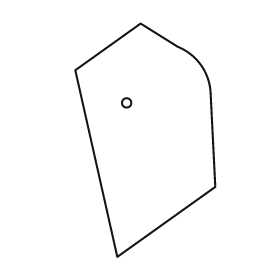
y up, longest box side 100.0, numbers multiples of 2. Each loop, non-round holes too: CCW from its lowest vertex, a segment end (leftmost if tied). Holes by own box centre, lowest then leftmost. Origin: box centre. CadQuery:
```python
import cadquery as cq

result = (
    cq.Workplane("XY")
    .moveTo(-12.0, -50.0)
    .lineTo(30.0, -20.0)
    .lineTo(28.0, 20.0)
    .threePointArc((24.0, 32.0), (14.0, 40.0))
    .lineTo(-2.0, 50.0)
    .lineTo(-30.0, 30.0)
    .close()
    .moveTo(-8.0, 16.0)
    .circle(2.0)
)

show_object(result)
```